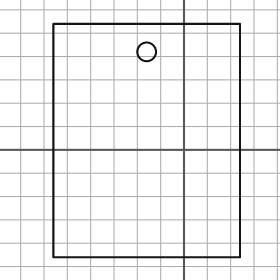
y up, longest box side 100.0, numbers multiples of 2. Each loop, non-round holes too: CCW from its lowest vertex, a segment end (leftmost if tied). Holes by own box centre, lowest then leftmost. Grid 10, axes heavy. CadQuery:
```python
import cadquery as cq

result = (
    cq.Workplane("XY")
    .moveTo(-56.0, -46.0)
    .lineTo(24.0, -46.0)
    .lineTo(24.0, 54.0)
    .lineTo(-56.0, 54.0)
    .close()
    .moveTo(-16.0, 42.0)
    .circle(4.0)
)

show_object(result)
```